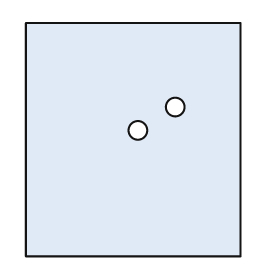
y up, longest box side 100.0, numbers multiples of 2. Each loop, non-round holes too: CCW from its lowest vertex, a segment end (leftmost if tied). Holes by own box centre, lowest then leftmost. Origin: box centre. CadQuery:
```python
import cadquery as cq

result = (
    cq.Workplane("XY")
    .moveTo(-46.0, -50.0)
    .lineTo(46.0, -50.0)
    .lineTo(46.0, 50.0)
    .lineTo(-46.0, 50.0)
    .close()
    .moveTo(2.0, 4.0)
    .circle(4.0)
    .moveTo(18.0, 14.0)
    .circle(4.0)
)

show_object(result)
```